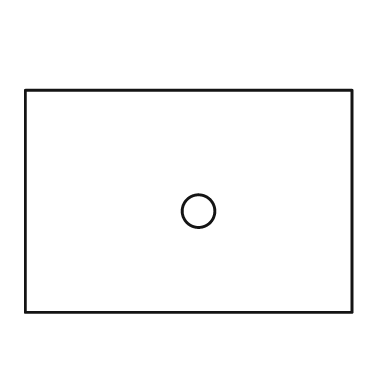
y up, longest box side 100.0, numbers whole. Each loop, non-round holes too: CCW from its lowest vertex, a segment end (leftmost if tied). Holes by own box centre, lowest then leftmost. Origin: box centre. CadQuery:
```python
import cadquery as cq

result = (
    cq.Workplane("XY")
    .moveTo(-50.0, -34.0)
    .lineTo(50.0, -34.0)
    .lineTo(50.0, 34.0)
    .lineTo(-50.0, 34.0)
    .close()
    .moveTo(3.0, -3.0)
    .circle(5.0)
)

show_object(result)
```